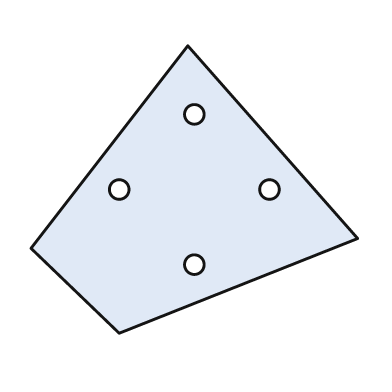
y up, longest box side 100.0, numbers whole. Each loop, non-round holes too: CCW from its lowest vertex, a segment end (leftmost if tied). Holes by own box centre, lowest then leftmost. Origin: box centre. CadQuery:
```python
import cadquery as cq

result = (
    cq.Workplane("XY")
    .moveTo(-23.0, -44.0)
    .lineTo(50.0, -15.0)
    .lineTo(-2.0, 44.0)
    .lineTo(-50.0, -18.0)
    .close()
    .moveTo(0.0, -23.0)
    .circle(3.0)
    .moveTo(-23.0, 0.0)
    .circle(3.0)
    .moveTo(23.0, 0.0)
    .circle(3.0)
    .moveTo(0.0, 23.0)
    .circle(3.0)
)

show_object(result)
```